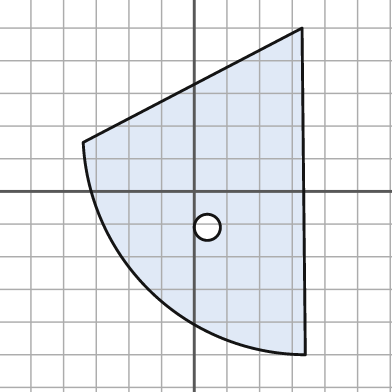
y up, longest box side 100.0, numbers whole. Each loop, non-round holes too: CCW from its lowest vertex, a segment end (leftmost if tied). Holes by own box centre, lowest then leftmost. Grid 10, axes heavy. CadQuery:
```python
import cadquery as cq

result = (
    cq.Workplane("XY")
    .moveTo(34.0, -50.0)
    .lineTo(33.0, 50.0)
    .lineTo(-34.0, 15.0)
    .threePointArc((-13.0, -31.0), (34.0, -50.0))
    .close()
    .moveTo(4.0, -11.0)
    .circle(4.0)
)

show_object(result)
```